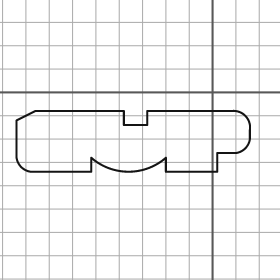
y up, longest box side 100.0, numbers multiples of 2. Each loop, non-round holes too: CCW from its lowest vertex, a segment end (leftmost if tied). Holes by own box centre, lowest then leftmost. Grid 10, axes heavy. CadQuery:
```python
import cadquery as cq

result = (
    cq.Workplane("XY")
    .moveTo(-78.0, -34.0)
    .lineTo(-52.0, -34.0)
    .lineTo(-52.0, -28.0)
    .threePointArc((-36.0, -34.0), (-20.0, -28.0))
    .lineTo(-20.0, -34.0)
    .lineTo(2.0, -34.0)
    .lineTo(2.0, -26.0)
    .lineTo(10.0, -26.0)
    .threePointArc((14.0, -24.0), (16.0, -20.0))
    .lineTo(16.0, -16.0)
    .threePointArc((14.0, -10.0), (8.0, -8.0))
    .lineTo(-28.0, -8.0)
    .lineTo(-28.0, -14.0)
    .lineTo(-38.0, -14.0)
    .lineTo(-38.0, -8.0)
    .lineTo(-76.0, -8.0)
    .lineTo(-84.0, -12.0)
    .lineTo(-84.0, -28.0)
    .threePointArc((-82.0, -32.0), (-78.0, -34.0))
    .close()
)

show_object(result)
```